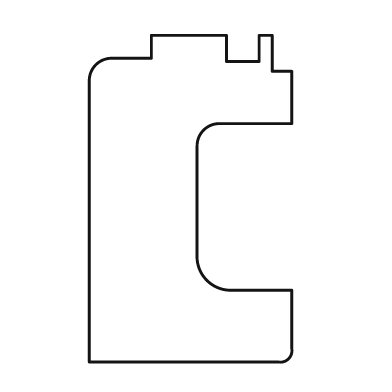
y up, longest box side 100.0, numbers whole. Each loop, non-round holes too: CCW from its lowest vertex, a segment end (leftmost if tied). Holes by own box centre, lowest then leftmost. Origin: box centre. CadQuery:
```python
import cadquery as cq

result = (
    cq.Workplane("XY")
    .moveTo(-31.0, -50.0)
    .lineTo(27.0, -50.0)
    .threePointArc((30.0, -49.0), (31.0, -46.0))
    .lineTo(31.0, -28.0)
    .lineTo(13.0, -28.0)
    .threePointArc((5.0, -25.0), (2.0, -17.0))
    .lineTo(2.0, 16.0)
    .threePointArc((4.0, 21.0), (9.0, 23.0))
    .lineTo(31.0, 23.0)
    .lineTo(31.0, 39.0)
    .lineTo(25.0, 39.0)
    .lineTo(25.0, 50.0)
    .lineTo(21.0, 50.0)
    .lineTo(21.0, 42.0)
    .lineTo(11.0, 42.0)
    .lineTo(11.0, 50.0)
    .lineTo(-12.0, 50.0)
    .lineTo(-12.0, 43.0)
    .lineTo(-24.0, 43.0)
    .threePointArc((-29.0, 41.0), (-31.0, 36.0))
    .close()
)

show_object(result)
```